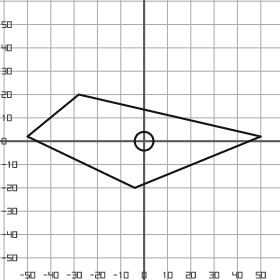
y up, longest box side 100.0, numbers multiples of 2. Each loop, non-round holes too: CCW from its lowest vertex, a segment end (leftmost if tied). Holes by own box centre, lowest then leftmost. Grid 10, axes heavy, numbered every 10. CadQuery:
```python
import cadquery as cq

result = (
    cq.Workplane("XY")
    .moveTo(-4.0, -20.0)
    .lineTo(50.0, 2.0)
    .lineTo(-28.0, 20.0)
    .lineTo(-50.0, 2.0)
    .close()
    .moveTo(0.0, 0.0)
    .circle(4.0)
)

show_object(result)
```